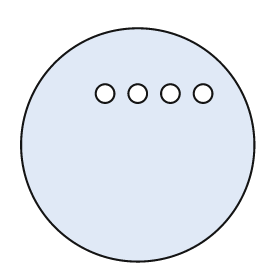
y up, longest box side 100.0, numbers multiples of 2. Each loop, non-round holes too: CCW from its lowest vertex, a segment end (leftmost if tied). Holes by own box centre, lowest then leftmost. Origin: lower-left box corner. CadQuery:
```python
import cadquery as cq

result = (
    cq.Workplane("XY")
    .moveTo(50.0, 50.0)
    .circle(50.0)
    .moveTo(36.0, 72.0)
    .circle(4.0)
    .moveTo(50.0, 72.0)
    .circle(4.0)
    .moveTo(64.0, 72.0)
    .circle(4.0)
    .moveTo(78.0, 72.0)
    .circle(4.0)
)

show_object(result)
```